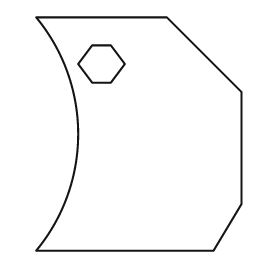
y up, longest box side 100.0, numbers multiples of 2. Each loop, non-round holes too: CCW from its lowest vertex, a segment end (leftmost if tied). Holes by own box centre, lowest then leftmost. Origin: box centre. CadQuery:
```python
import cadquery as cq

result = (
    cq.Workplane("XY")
    .moveTo(-44.0, -50.0)
    .lineTo(32.0, -50.0)
    .lineTo(44.0, -30.0)
    .lineTo(44.0, 18.0)
    .lineTo(12.0, 50.0)
    .lineTo(-44.0, 50.0)
    .threePointArc((-26.0, 0.0), (-44.0, -50.0))
    .close()
    .moveTo(-20.0, 22.0)
    .lineTo(-12.0, 22.0)
    .lineTo(-6.0, 30.0)
    .lineTo(-12.0, 38.0)
    .lineTo(-20.0, 38.0)
    .lineTo(-26.0, 30.0)
    .close()
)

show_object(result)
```